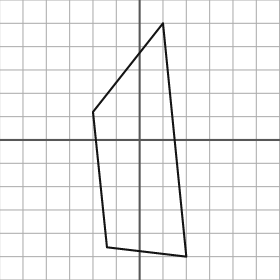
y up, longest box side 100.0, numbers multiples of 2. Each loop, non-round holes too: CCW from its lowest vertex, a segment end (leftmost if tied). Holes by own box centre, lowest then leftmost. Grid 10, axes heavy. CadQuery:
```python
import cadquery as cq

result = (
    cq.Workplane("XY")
    .moveTo(20.0, -50.0)
    .lineTo(10.0, 50.0)
    .lineTo(-20.0, 12.0)
    .lineTo(-14.0, -46.0)
    .close()
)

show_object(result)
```